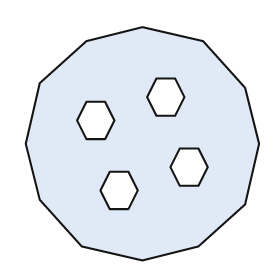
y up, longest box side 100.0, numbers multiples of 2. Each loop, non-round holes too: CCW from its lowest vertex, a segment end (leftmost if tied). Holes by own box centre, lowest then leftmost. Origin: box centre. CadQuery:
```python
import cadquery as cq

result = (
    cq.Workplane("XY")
    .moveTo(0.0, -50.0)
    .lineTo(24.0, -44.0)
    .lineTo(44.0, -26.0)
    .lineTo(50.0, 0.0)
    .lineTo(44.0, 24.0)
    .lineTo(26.0, 44.0)
    .lineTo(0.0, 50.0)
    .lineTo(-24.0, 44.0)
    .lineTo(-44.0, 26.0)
    .lineTo(-50.0, 0.0)
    .lineTo(-44.0, -24.0)
    .lineTo(-26.0, -44.0)
    .close()
    .moveTo(-14.0, -28.0)
    .lineTo(-6.0, -28.0)
    .lineTo(-2.0, -20.0)
    .lineTo(-6.0, -12.0)
    .lineTo(-14.0, -12.0)
    .lineTo(-18.0, -20.0)
    .close()
    .moveTo(16.0, -18.0)
    .lineTo(24.0, -18.0)
    .lineTo(28.0, -10.0)
    .lineTo(24.0, -2.0)
    .lineTo(16.0, -2.0)
    .lineTo(12.0, -10.0)
    .close()
    .moveTo(-24.0, 2.0)
    .lineTo(-16.0, 2.0)
    .lineTo(-12.0, 10.0)
    .lineTo(-16.0, 18.0)
    .lineTo(-24.0, 18.0)
    .lineTo(-28.0, 10.0)
    .close()
    .moveTo(6.0, 12.0)
    .lineTo(14.0, 12.0)
    .lineTo(18.0, 20.0)
    .lineTo(14.0, 28.0)
    .lineTo(6.0, 28.0)
    .lineTo(2.0, 20.0)
    .close()
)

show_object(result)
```